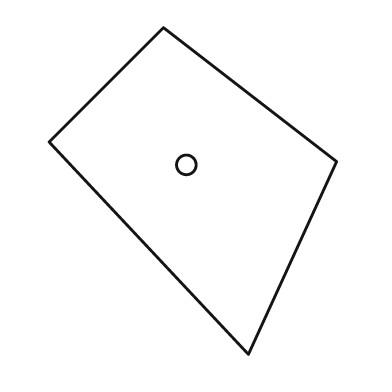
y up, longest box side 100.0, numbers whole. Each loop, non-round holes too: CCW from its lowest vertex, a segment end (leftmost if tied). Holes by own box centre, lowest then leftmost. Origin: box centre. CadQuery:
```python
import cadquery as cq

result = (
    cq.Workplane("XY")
    .moveTo(17.0, -50.0)
    .lineTo(44.0, 9.0)
    .lineTo(-9.0, 50.0)
    .lineTo(-44.0, 15.0)
    .close()
    .moveTo(-2.0, 8.0)
    .circle(3.0)
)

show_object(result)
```